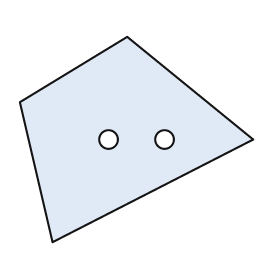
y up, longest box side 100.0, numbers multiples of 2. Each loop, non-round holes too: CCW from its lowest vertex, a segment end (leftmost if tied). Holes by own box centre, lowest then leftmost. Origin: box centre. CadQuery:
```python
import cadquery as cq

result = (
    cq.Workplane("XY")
    .moveTo(-36.0, -44.0)
    .lineTo(50.0, 0.0)
    .lineTo(-4.0, 44.0)
    .lineTo(-50.0, 16.0)
    .close()
    .moveTo(-12.0, 0.0)
    .circle(4.0)
    .moveTo(12.0, 0.0)
    .circle(4.0)
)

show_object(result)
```